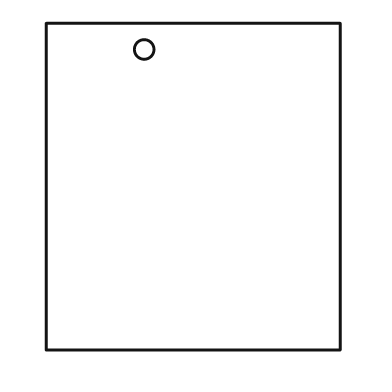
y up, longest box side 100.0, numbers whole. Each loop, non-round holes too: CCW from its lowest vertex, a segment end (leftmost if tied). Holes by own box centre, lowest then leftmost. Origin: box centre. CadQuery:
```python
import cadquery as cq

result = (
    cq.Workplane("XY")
    .moveTo(-45.0, -50.0)
    .lineTo(45.0, -50.0)
    .lineTo(45.0, 50.0)
    .lineTo(-45.0, 50.0)
    .close()
    .moveTo(-15.0, 42.0)
    .circle(3.0)
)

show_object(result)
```